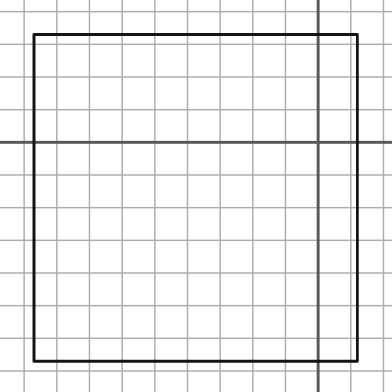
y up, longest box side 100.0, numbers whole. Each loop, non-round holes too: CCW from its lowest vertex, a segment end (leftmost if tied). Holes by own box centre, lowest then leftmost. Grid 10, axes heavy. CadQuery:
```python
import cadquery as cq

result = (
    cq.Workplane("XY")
    .moveTo(-87.0, -67.0)
    .lineTo(12.0, -67.0)
    .lineTo(12.0, 33.0)
    .lineTo(-87.0, 33.0)
    .close()
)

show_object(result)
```